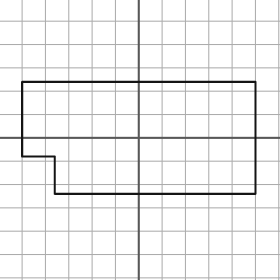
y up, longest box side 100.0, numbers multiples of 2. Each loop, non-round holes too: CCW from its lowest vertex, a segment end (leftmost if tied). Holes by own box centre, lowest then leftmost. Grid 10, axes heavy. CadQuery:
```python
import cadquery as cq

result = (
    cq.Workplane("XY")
    .moveTo(-36.0, -24.0)
    .lineTo(50.0, -24.0)
    .lineTo(50.0, 24.0)
    .lineTo(-50.0, 24.0)
    .lineTo(-50.0, -8.0)
    .lineTo(-36.0, -8.0)
    .close()
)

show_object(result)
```